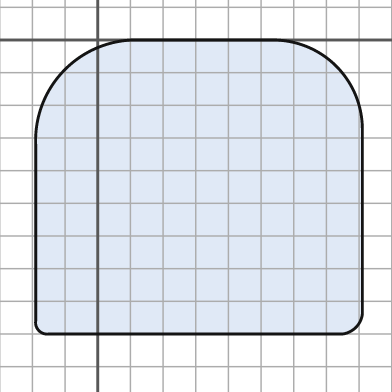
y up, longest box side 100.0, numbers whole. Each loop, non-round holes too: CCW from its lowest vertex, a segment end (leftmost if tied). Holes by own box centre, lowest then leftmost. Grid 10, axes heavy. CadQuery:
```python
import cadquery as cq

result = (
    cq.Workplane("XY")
    .moveTo(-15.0, -90.0)
    .lineTo(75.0, -90.0)
    .threePointArc((79.0, -88.0), (81.0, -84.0))
    .lineTo(81.0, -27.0)
    .threePointArc((73.0, -8.0), (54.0, 0.0))
    .lineTo(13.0, 0.0)
    .threePointArc((-10.0, -9.0), (-19.0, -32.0))
    .lineTo(-19.0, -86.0)
    .threePointArc((-18.0, -89.0), (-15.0, -90.0))
    .close()
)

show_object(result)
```